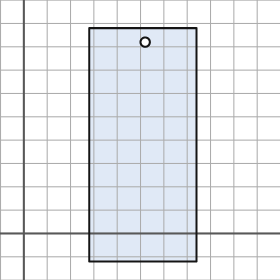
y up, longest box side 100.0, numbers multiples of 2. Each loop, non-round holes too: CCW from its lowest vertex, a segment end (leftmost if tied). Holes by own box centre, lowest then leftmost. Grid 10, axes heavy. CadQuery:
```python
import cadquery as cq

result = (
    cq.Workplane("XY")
    .moveTo(28.0, -12.0)
    .lineTo(74.0, -12.0)
    .lineTo(74.0, 88.0)
    .lineTo(28.0, 88.0)
    .close()
    .moveTo(52.0, 82.0)
    .circle(2.0)
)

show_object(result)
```